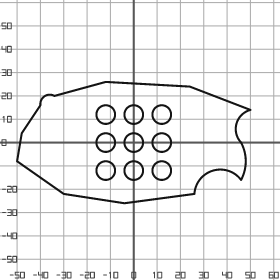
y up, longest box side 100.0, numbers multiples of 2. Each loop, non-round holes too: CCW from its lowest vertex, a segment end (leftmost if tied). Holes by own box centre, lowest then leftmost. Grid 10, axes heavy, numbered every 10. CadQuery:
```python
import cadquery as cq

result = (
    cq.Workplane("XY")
    .moveTo(-4.0, -26.0)
    .lineTo(26.0, -22.0)
    .threePointArc((34.0, -12.0), (46.0, -16.0))
    .threePointArc((48.0, -8.0), (46.0, 0.0))
    .threePointArc((44.0, 8.0), (50.0, 14.0))
    .lineTo(24.0, 24.0)
    .lineTo(-12.0, 26.0)
    .lineTo(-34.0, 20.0)
    .threePointArc((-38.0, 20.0), (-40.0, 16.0))
    .lineTo(-48.0, 4.0)
    .lineTo(-50.0, -8.0)
    .lineTo(-30.0, -22.0)
    .close()
    .moveTo(-12.0, -12.0)
    .circle(4.0)
    .moveTo(0.0, -12.0)
    .circle(4.0)
    .moveTo(12.0, -12.0)
    .circle(4.0)
    .moveTo(-12.0, 0.0)
    .circle(4.0)
    .moveTo(0.0, 0.0)
    .circle(4.0)
    .moveTo(12.0, 0.0)
    .circle(4.0)
    .moveTo(-12.0, 12.0)
    .circle(4.0)
    .moveTo(0.0, 12.0)
    .circle(4.0)
    .moveTo(12.0, 12.0)
    .circle(4.0)
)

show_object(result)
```